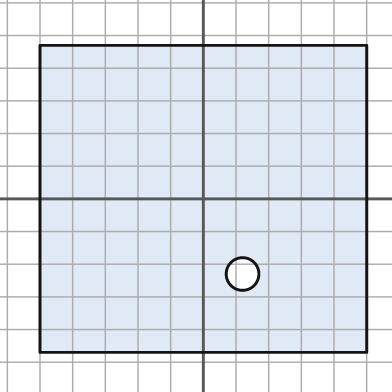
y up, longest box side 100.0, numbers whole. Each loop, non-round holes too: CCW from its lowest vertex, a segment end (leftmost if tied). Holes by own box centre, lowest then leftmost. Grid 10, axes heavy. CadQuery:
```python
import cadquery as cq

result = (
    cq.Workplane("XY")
    .moveTo(-50.0, -47.0)
    .lineTo(50.0, -47.0)
    .lineTo(50.0, 47.0)
    .lineTo(-50.0, 47.0)
    .close()
    .moveTo(12.0, -23.0)
    .circle(5.0)
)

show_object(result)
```